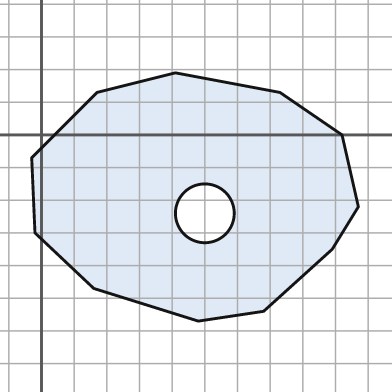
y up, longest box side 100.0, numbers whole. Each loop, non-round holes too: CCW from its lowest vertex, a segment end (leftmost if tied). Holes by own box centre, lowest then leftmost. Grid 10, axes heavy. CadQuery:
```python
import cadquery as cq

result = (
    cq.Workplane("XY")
    .moveTo(48.0, -57.0)
    .lineTo(68.0, -54.0)
    .lineTo(89.0, -35.0)
    .lineTo(97.0, -22.0)
    .lineTo(92.0, 0.0)
    .lineTo(73.0, 13.0)
    .lineTo(41.0, 19.0)
    .lineTo(17.0, 13.0)
    .lineTo(-3.0, -7.0)
    .lineTo(-2.0, -30.0)
    .lineTo(16.0, -47.0)
    .close()
    .moveTo(50.0, -24.0)
    .circle(9.0)
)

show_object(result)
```